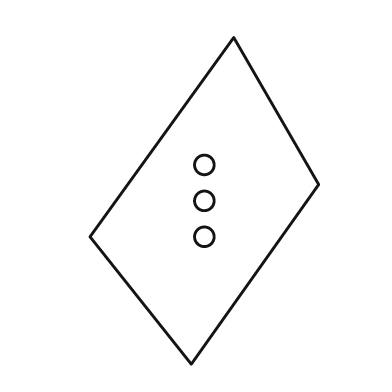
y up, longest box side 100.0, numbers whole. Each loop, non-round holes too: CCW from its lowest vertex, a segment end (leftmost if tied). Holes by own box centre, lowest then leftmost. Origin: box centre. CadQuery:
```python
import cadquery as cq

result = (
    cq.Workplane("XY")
    .moveTo(-4.0, -50.0)
    .lineTo(35.0, 5.0)
    .lineTo(9.0, 50.0)
    .lineTo(-35.0, -11.0)
    .close()
    .moveTo(0.0, -11.0)
    .circle(3.0)
    .moveTo(0.0, 0.0)
    .circle(3.0)
    .moveTo(0.0, 11.0)
    .circle(3.0)
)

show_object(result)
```